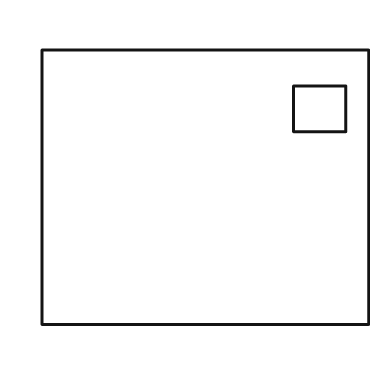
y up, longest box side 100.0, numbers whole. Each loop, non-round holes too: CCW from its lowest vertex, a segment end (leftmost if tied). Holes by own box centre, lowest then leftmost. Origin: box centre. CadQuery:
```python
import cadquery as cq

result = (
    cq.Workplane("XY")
    .moveTo(-50.0, -42.0)
    .lineTo(50.0, -42.0)
    .lineTo(50.0, 42.0)
    .lineTo(-50.0, 42.0)
    .close()
    .moveTo(27.0, 17.0)
    .lineTo(43.0, 17.0)
    .lineTo(43.0, 31.0)
    .lineTo(27.0, 31.0)
    .close()
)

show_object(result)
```